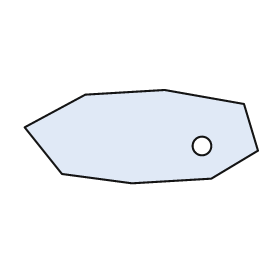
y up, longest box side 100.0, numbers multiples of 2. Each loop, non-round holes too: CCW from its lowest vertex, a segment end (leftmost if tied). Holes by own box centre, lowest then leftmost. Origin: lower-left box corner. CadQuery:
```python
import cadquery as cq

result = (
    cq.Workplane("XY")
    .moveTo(46.0, 0.0)
    .lineTo(80.0, 2.0)
    .lineTo(100.0, 14.0)
    .lineTo(94.0, 34.0)
    .lineTo(60.0, 40.0)
    .lineTo(26.0, 38.0)
    .lineTo(0.0, 24.0)
    .lineTo(16.0, 4.0)
    .close()
    .moveTo(76.0, 16.0)
    .circle(4.0)
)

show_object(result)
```